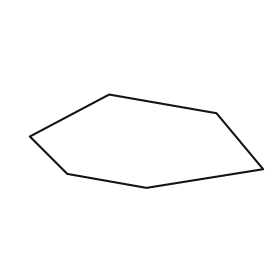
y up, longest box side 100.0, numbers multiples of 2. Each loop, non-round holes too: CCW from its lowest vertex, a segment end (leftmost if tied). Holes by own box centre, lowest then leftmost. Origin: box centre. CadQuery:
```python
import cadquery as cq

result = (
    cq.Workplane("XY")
    .moveTo(0.0, -20.0)
    .lineTo(50.0, -12.0)
    .lineTo(30.0, 12.0)
    .lineTo(-16.0, 20.0)
    .lineTo(-50.0, 2.0)
    .lineTo(-34.0, -14.0)
    .close()
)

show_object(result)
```